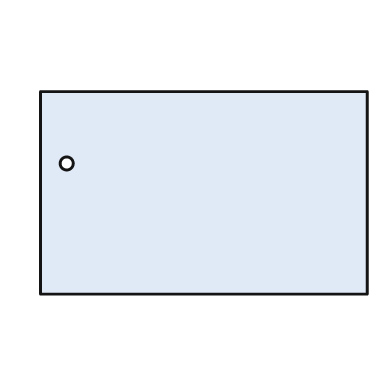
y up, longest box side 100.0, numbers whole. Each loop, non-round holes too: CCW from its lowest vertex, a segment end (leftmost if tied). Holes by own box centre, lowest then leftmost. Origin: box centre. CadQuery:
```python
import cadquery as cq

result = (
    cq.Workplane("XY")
    .moveTo(-50.0, -31.0)
    .lineTo(50.0, -31.0)
    .lineTo(50.0, 31.0)
    .lineTo(-50.0, 31.0)
    .close()
    .moveTo(-42.0, 9.0)
    .circle(2.0)
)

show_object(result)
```